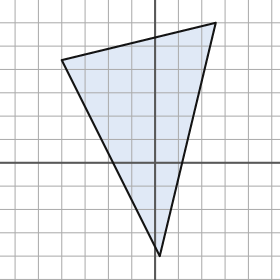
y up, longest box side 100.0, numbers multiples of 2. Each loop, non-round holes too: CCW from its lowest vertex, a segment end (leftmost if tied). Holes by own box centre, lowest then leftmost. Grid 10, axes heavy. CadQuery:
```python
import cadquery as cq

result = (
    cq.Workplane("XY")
    .moveTo(2.0, -40.0)
    .lineTo(26.0, 60.0)
    .lineTo(-40.0, 44.0)
    .close()
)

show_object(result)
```